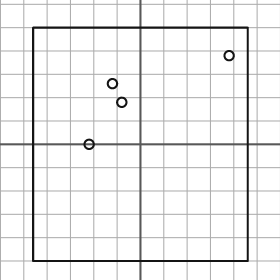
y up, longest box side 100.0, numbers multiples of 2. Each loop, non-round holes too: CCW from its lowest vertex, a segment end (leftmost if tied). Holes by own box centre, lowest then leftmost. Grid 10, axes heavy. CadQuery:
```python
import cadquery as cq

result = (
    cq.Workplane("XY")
    .moveTo(-46.0, -50.0)
    .lineTo(46.0, -50.0)
    .lineTo(46.0, 50.0)
    .lineTo(-46.0, 50.0)
    .close()
    .moveTo(-22.0, 0.0)
    .circle(2.0)
    .moveTo(-8.0, 18.0)
    .circle(2.0)
    .moveTo(-12.0, 26.0)
    .circle(2.0)
    .moveTo(38.0, 38.0)
    .circle(2.0)
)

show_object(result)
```